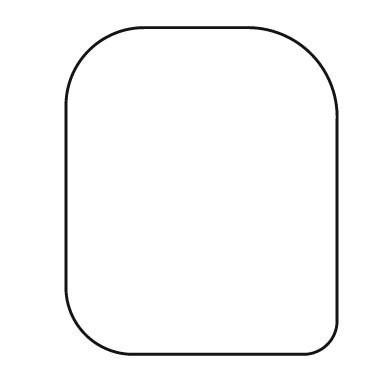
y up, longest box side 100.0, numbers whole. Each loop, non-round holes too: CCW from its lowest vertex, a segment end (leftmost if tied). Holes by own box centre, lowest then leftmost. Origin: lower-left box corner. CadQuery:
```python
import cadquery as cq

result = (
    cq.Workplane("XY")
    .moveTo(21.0, 0.0)
    .lineTo(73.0, 0.0)
    .threePointArc((80.0, 3.0), (83.0, 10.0))
    .lineTo(83.0, 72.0)
    .threePointArc((75.0, 92.0), (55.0, 100.0))
    .lineTo(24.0, 100.0)
    .threePointArc((7.0, 93.0), (0.0, 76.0))
    .lineTo(0.0, 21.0)
    .threePointArc((6.0, 6.0), (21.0, 0.0))
    .close()
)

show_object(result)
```